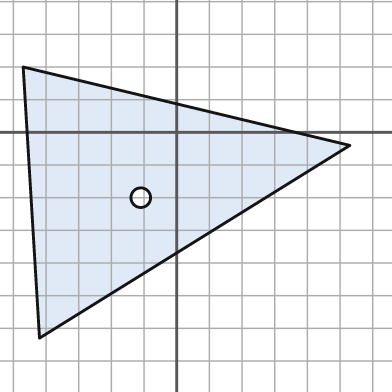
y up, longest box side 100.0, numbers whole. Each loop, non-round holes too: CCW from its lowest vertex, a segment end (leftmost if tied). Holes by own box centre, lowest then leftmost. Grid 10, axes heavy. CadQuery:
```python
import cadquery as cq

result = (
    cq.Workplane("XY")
    .moveTo(-42.0, -63.0)
    .lineTo(53.0, -4.0)
    .lineTo(-47.0, 20.0)
    .close()
    .moveTo(-11.0, -20.0)
    .circle(3.0)
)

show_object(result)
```